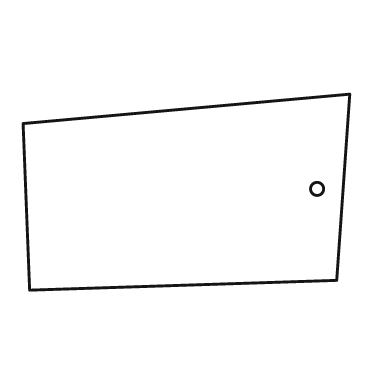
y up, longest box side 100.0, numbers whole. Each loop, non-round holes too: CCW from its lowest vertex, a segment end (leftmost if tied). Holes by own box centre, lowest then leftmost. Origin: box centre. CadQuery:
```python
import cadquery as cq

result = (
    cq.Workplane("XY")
    .moveTo(-48.0, -30.0)
    .lineTo(46.0, -27.0)
    .lineTo(50.0, 30.0)
    .lineTo(-50.0, 21.0)
    .close()
    .moveTo(40.0, 1.0)
    .circle(2.0)
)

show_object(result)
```